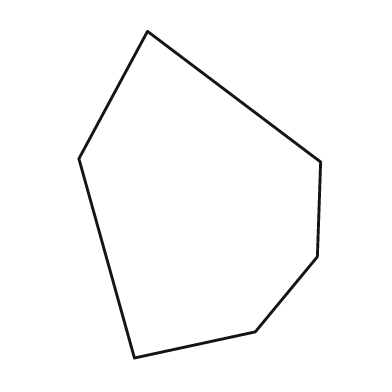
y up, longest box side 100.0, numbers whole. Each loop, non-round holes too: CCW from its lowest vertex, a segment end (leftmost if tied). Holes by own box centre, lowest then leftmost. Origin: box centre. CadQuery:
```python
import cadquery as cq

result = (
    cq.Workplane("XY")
    .moveTo(-20.0, -50.0)
    .lineTo(17.0, -42.0)
    .lineTo(36.0, -19.0)
    .lineTo(37.0, 10.0)
    .lineTo(-16.0, 50.0)
    .lineTo(-37.0, 11.0)
    .close()
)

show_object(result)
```